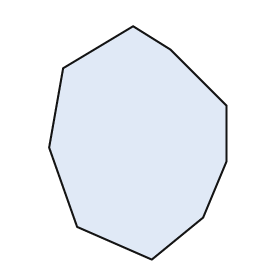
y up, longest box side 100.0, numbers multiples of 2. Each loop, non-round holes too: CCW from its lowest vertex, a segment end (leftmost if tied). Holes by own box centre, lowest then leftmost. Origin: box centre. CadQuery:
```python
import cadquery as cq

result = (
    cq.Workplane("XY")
    .moveTo(6.0, -50.0)
    .lineTo(28.0, -32.0)
    .lineTo(38.0, -8.0)
    .lineTo(38.0, 16.0)
    .lineTo(14.0, 40.0)
    .lineTo(-2.0, 50.0)
    .lineTo(-32.0, 32.0)
    .lineTo(-38.0, -2.0)
    .lineTo(-26.0, -36.0)
    .close()
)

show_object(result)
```